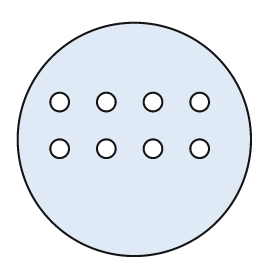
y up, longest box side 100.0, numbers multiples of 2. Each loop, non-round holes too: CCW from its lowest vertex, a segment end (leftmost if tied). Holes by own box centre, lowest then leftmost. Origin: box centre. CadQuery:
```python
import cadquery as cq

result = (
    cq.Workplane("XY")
    .moveTo(0.0, 0.0)
    .circle(50.0)
    .moveTo(-32.0, -4.0)
    .circle(4.0)
    .moveTo(-12.0, -4.0)
    .circle(4.0)
    .moveTo(8.0, -4.0)
    .circle(4.0)
    .moveTo(28.0, -4.0)
    .circle(4.0)
    .moveTo(-32.0, 16.0)
    .circle(4.0)
    .moveTo(-12.0, 16.0)
    .circle(4.0)
    .moveTo(8.0, 16.0)
    .circle(4.0)
    .moveTo(28.0, 16.0)
    .circle(4.0)
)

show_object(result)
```